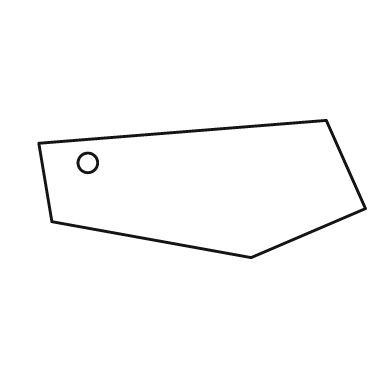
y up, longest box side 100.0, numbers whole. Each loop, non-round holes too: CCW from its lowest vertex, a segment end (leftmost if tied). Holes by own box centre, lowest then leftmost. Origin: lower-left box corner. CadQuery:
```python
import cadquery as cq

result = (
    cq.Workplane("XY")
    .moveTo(65.0, 0.0)
    .lineTo(100.0, 15.0)
    .lineTo(88.0, 42.0)
    .lineTo(0.0, 35.0)
    .lineTo(4.0, 11.0)
    .close()
    .moveTo(15.0, 29.0)
    .circle(3.0)
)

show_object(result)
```